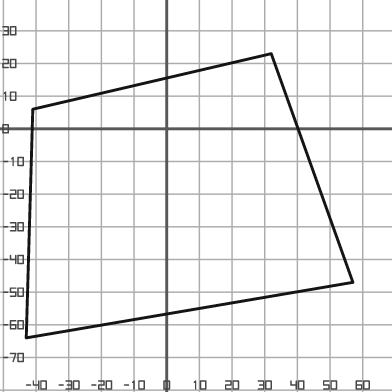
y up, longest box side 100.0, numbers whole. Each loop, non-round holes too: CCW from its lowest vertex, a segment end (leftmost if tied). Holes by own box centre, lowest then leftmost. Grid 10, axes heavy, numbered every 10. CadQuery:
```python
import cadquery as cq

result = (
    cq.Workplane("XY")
    .moveTo(-43.0, -64.0)
    .lineTo(57.0, -47.0)
    .lineTo(32.0, 23.0)
    .lineTo(-41.0, 6.0)
    .close()
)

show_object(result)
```